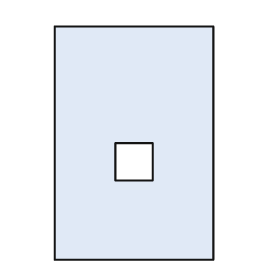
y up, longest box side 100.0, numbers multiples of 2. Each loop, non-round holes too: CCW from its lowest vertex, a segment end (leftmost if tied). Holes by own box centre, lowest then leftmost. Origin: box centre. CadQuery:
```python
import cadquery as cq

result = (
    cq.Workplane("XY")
    .moveTo(-34.0, -50.0)
    .lineTo(34.0, -50.0)
    .lineTo(34.0, 50.0)
    .lineTo(-34.0, 50.0)
    .close()
    .moveTo(-8.0, -16.0)
    .lineTo(8.0, -16.0)
    .lineTo(8.0, 0.0)
    .lineTo(-8.0, 0.0)
    .close()
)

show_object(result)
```